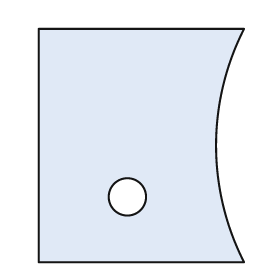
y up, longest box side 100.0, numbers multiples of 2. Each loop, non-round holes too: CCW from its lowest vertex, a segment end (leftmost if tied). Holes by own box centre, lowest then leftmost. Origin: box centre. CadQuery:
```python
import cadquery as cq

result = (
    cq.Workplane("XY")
    .moveTo(-44.0, -50.0)
    .lineTo(44.0, -50.0)
    .threePointArc((32.0, 0.0), (44.0, 50.0))
    .lineTo(-44.0, 50.0)
    .close()
    .moveTo(-6.0, -22.0)
    .circle(8.0)
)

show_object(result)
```